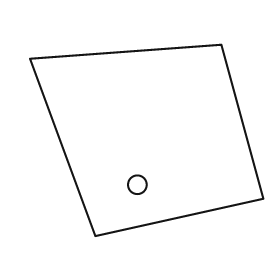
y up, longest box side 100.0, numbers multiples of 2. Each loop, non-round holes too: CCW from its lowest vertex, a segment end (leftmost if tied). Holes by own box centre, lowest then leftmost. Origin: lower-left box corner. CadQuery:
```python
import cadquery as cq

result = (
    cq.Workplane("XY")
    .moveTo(28.0, 0.0)
    .lineTo(100.0, 16.0)
    .lineTo(82.0, 82.0)
    .lineTo(0.0, 76.0)
    .close()
    .moveTo(46.0, 22.0)
    .circle(4.0)
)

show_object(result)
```